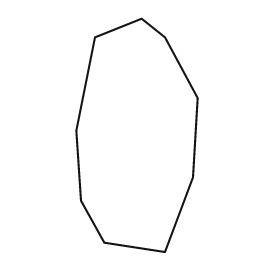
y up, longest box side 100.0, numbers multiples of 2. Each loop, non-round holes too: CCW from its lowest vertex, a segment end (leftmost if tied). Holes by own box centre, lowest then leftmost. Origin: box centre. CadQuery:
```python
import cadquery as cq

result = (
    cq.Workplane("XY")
    .moveTo(12.0, -50.0)
    .lineTo(24.0, -18.0)
    .lineTo(26.0, 16.0)
    .lineTo(12.0, 42.0)
    .lineTo(2.0, 50.0)
    .lineTo(-18.0, 42.0)
    .lineTo(-26.0, 2.0)
    .lineTo(-24.0, -28.0)
    .lineTo(-14.0, -46.0)
    .close()
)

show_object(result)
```